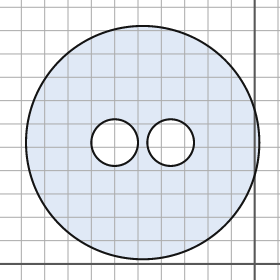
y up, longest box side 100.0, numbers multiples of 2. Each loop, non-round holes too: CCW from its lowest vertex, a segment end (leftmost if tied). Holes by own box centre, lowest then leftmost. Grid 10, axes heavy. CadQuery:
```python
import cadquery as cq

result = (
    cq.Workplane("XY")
    .moveTo(-48.0, 52.0)
    .circle(50.0)
    .moveTo(-60.0, 52.0)
    .circle(10.0)
    .moveTo(-36.0, 52.0)
    .circle(10.0)
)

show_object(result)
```